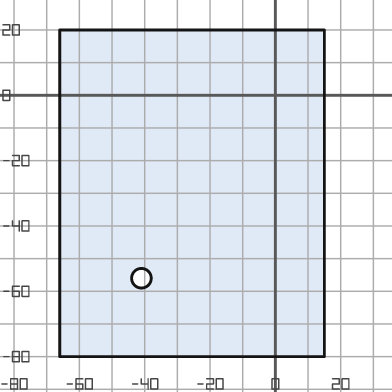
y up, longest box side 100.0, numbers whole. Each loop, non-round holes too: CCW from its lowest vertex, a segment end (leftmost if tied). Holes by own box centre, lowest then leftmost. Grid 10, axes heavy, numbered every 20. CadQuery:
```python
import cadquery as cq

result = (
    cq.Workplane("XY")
    .moveTo(-66.0, -80.0)
    .lineTo(15.0, -80.0)
    .lineTo(15.0, 20.0)
    .lineTo(-66.0, 20.0)
    .close()
    .moveTo(-41.0, -56.0)
    .circle(3.0)
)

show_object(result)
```